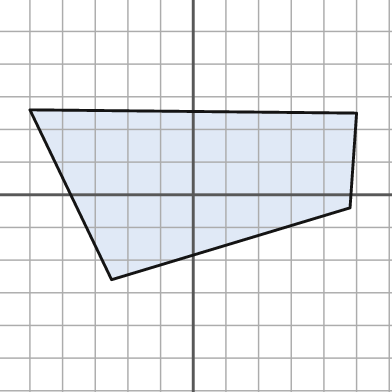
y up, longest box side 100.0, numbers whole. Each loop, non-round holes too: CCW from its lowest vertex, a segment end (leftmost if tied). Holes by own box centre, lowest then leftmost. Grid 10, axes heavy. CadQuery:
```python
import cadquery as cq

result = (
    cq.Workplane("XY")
    .moveTo(-25.0, -26.0)
    .lineTo(48.0, -4.0)
    .lineTo(50.0, 25.0)
    .lineTo(-50.0, 26.0)
    .close()
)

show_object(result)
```